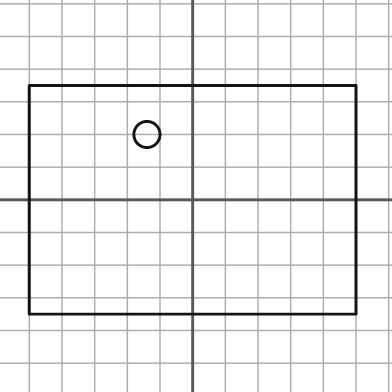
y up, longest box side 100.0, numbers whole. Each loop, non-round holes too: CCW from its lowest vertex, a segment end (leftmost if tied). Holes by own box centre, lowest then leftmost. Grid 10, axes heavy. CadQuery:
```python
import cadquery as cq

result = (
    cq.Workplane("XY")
    .moveTo(-50.0, -35.0)
    .lineTo(50.0, -35.0)
    .lineTo(50.0, 35.0)
    .lineTo(-50.0, 35.0)
    .close()
    .moveTo(-14.0, 20.0)
    .circle(4.0)
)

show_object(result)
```